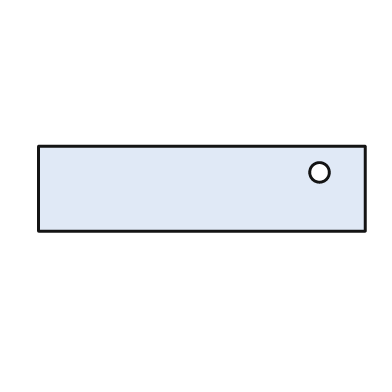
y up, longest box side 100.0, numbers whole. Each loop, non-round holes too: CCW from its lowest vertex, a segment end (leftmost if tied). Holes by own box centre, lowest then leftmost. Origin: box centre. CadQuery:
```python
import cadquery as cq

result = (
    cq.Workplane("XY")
    .moveTo(-50.0, -13.0)
    .lineTo(50.0, -13.0)
    .lineTo(50.0, 13.0)
    .lineTo(-50.0, 13.0)
    .close()
    .moveTo(36.0, 5.0)
    .circle(3.0)
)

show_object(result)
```